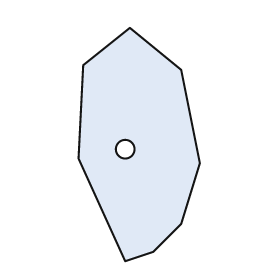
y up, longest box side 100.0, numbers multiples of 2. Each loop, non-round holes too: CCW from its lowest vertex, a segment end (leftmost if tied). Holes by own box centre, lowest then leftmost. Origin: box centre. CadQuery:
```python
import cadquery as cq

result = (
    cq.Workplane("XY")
    .moveTo(-6.0, -50.0)
    .lineTo(6.0, -46.0)
    .lineTo(18.0, -34.0)
    .lineTo(26.0, -8.0)
    .lineTo(18.0, 32.0)
    .lineTo(-4.0, 50.0)
    .lineTo(-24.0, 34.0)
    .lineTo(-26.0, -6.0)
    .close()
    .moveTo(-6.0, -2.0)
    .circle(4.0)
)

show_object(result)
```